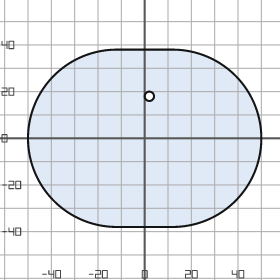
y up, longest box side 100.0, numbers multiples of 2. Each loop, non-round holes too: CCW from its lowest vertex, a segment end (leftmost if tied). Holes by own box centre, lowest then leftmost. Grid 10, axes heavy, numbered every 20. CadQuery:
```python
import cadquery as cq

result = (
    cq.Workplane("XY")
    .moveTo(-12.0, -38.0)
    .lineTo(12.0, -38.0)
    .threePointArc((50.0, 0.0), (12.0, 38.0))
    .lineTo(-12.0, 38.0)
    .threePointArc((-50.0, 0.0), (-12.0, -38.0))
    .close()
    .moveTo(2.0, 18.0)
    .circle(2.0)
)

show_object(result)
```